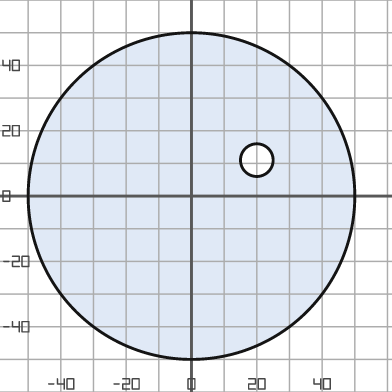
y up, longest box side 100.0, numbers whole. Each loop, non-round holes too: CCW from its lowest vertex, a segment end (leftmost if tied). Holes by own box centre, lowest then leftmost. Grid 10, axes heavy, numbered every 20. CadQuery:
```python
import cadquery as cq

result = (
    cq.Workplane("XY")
    .moveTo(0.0, 0.0)
    .circle(50.0)
    .moveTo(20.0, 11.0)
    .circle(5.0)
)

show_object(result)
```